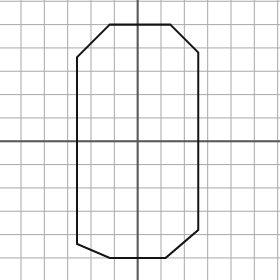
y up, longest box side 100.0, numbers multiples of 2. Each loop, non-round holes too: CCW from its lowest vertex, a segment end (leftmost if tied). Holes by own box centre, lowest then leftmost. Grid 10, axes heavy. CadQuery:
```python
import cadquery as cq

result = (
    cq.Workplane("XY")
    .moveTo(-12.0, -50.0)
    .lineTo(12.0, -50.0)
    .lineTo(26.0, -38.0)
    .lineTo(26.0, 38.0)
    .lineTo(14.0, 50.0)
    .lineTo(-12.0, 50.0)
    .lineTo(-26.0, 36.0)
    .lineTo(-26.0, -44.0)
    .close()
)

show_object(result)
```